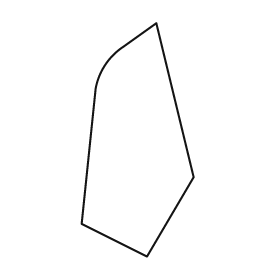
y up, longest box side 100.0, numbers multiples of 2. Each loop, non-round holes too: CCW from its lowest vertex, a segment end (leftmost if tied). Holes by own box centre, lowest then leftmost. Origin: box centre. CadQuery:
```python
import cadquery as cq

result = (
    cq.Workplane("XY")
    .moveTo(4.0, -50.0)
    .lineTo(24.0, -16.0)
    .lineTo(8.0, 50.0)
    .lineTo(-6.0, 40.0)
    .threePointArc((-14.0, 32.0), (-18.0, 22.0))
    .lineTo(-24.0, -36.0)
    .close()
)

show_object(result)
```